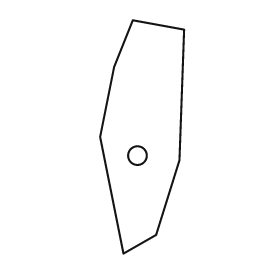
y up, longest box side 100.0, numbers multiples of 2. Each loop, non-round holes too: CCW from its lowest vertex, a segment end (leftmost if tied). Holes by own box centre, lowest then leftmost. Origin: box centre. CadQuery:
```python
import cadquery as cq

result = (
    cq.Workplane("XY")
    .moveTo(-8.0, -50.0)
    .lineTo(6.0, -42.0)
    .lineTo(16.0, -10.0)
    .lineTo(18.0, 46.0)
    .lineTo(-4.0, 50.0)
    .lineTo(-12.0, 30.0)
    .lineTo(-18.0, 0.0)
    .close()
    .moveTo(-2.0, -8.0)
    .circle(4.0)
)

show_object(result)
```